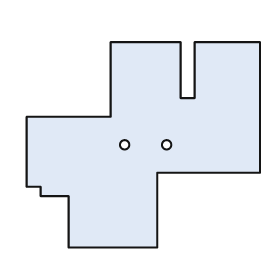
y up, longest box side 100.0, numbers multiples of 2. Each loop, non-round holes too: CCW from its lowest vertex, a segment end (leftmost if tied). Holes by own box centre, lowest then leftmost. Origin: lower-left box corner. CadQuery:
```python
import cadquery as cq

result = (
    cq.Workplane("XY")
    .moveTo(18.0, 0.0)
    .lineTo(56.0, 0.0)
    .lineTo(56.0, 32.0)
    .lineTo(100.0, 32.0)
    .lineTo(100.0, 88.0)
    .lineTo(72.0, 88.0)
    .lineTo(72.0, 64.0)
    .lineTo(66.0, 64.0)
    .lineTo(66.0, 88.0)
    .lineTo(36.0, 88.0)
    .lineTo(36.0, 56.0)
    .lineTo(0.0, 56.0)
    .lineTo(0.0, 26.0)
    .lineTo(6.0, 26.0)
    .lineTo(6.0, 22.0)
    .lineTo(18.0, 22.0)
    .close()
    .moveTo(42.0, 44.0)
    .circle(2.0)
    .moveTo(60.0, 44.0)
    .circle(2.0)
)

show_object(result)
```